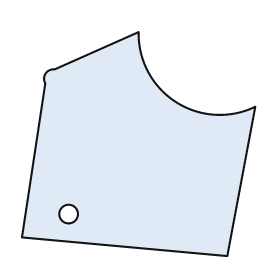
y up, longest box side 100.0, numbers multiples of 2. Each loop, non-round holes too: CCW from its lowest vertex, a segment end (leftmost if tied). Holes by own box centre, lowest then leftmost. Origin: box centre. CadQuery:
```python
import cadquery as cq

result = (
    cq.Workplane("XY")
    .moveTo(38.0, -48.0)
    .lineTo(50.0, 16.0)
    .threePointArc((16.0, 18.0), (0.0, 48.0))
    .lineTo(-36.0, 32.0)
    .threePointArc((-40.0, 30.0), (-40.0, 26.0))
    .lineTo(-50.0, -40.0)
    .close()
    .moveTo(-30.0, -30.0)
    .circle(4.0)
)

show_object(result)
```